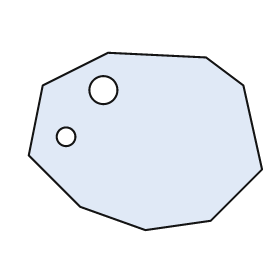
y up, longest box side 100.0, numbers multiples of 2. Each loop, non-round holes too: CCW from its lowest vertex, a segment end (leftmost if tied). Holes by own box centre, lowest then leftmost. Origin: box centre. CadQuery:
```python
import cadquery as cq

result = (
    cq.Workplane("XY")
    .moveTo(0.0, -38.0)
    .lineTo(28.0, -34.0)
    .lineTo(50.0, -12.0)
    .lineTo(42.0, 24.0)
    .lineTo(26.0, 36.0)
    .lineTo(-16.0, 38.0)
    .lineTo(-44.0, 24.0)
    .lineTo(-50.0, -6.0)
    .lineTo(-28.0, -28.0)
    .close()
    .moveTo(-34.0, 2.0)
    .circle(4.0)
    .moveTo(-18.0, 22.0)
    .circle(6.0)
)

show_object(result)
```